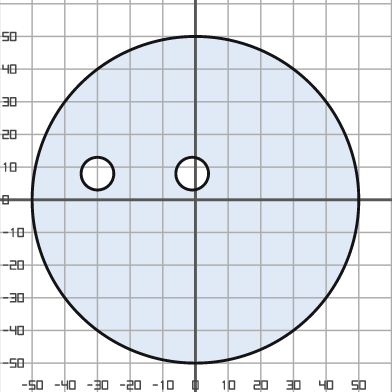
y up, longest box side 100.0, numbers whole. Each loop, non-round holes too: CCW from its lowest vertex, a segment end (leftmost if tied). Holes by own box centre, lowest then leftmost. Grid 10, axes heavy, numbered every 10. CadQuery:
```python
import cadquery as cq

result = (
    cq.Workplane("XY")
    .moveTo(0.0, 0.0)
    .circle(50.0)
    .moveTo(-30.0, 8.0)
    .circle(5.0)
    .moveTo(-1.0, 8.0)
    .circle(5.0)
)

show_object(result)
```